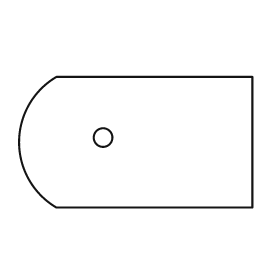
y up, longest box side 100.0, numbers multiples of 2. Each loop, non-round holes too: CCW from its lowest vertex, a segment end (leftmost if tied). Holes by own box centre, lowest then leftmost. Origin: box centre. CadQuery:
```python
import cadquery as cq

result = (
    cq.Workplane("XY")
    .moveTo(-34.0, -28.0)
    .lineTo(50.0, -28.0)
    .lineTo(50.0, 28.0)
    .lineTo(-34.0, 28.0)
    .threePointArc((-50.0, 0.0), (-34.0, -28.0))
    .close()
    .moveTo(-14.0, 2.0)
    .circle(4.0)
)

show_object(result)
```